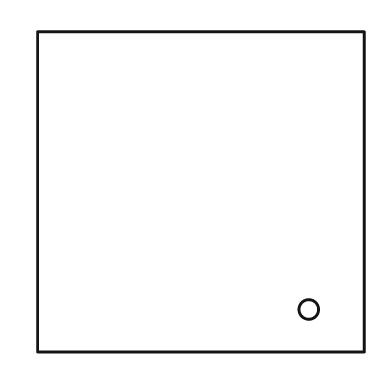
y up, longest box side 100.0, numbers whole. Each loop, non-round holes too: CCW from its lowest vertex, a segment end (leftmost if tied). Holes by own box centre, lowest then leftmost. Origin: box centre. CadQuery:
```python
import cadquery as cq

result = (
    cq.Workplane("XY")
    .moveTo(-50.0, -49.0)
    .lineTo(50.0, -49.0)
    .lineTo(50.0, 49.0)
    .lineTo(-50.0, 49.0)
    .close()
    .moveTo(33.0, -36.0)
    .circle(3.0)
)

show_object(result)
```